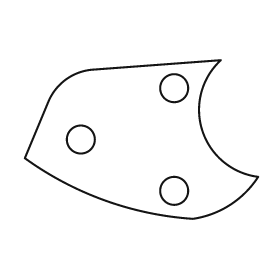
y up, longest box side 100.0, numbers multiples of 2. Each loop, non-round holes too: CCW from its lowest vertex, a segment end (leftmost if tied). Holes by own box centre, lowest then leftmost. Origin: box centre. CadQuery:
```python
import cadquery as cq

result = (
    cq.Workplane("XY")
    .moveTo(22.0, -34.0)
    .threePointArc((38.0, -28.0), (50.0, -16.0))
    .threePointArc((26.0, 4.0), (34.0, 34.0))
    .lineTo(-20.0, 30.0)
    .threePointArc((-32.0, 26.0), (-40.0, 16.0))
    .lineTo(-50.0, -8.0)
    .threePointArc((-16.0, -26.0), (22.0, -34.0))
    .close()
    .moveTo(14.0, -22.0)
    .circle(6.0)
    .moveTo(-26.0, 0.0)
    .circle(6.0)
    .moveTo(14.0, 22.0)
    .circle(6.0)
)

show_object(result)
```